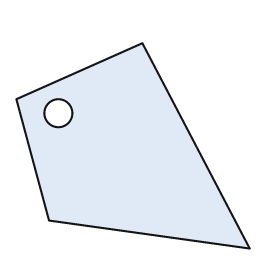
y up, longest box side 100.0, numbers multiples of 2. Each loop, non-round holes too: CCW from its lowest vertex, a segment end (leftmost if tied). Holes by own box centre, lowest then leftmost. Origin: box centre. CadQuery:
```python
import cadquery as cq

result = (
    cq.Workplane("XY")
    .moveTo(50.0, -44.0)
    .lineTo(4.0, 44.0)
    .lineTo(-50.0, 20.0)
    .lineTo(-36.0, -32.0)
    .close()
    .moveTo(-32.0, 14.0)
    .circle(6.0)
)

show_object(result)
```